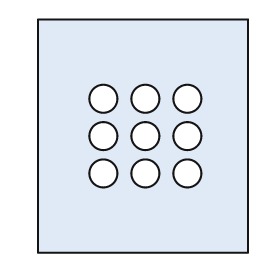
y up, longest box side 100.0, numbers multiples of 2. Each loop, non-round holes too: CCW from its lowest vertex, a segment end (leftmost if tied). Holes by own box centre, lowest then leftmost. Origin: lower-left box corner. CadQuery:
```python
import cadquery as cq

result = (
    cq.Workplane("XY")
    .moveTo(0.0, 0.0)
    .lineTo(90.0, 0.0)
    .lineTo(90.0, 100.0)
    .lineTo(0.0, 100.0)
    .close()
    .moveTo(28.0, 34.0)
    .circle(6.0)
    .moveTo(46.0, 34.0)
    .circle(6.0)
    .moveTo(64.0, 34.0)
    .circle(6.0)
    .moveTo(28.0, 50.0)
    .circle(6.0)
    .moveTo(46.0, 50.0)
    .circle(6.0)
    .moveTo(64.0, 50.0)
    .circle(6.0)
    .moveTo(28.0, 66.0)
    .circle(6.0)
    .moveTo(46.0, 66.0)
    .circle(6.0)
    .moveTo(64.0, 66.0)
    .circle(6.0)
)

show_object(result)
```